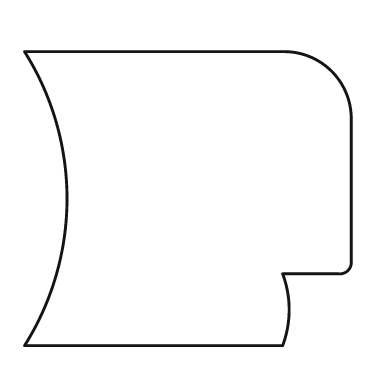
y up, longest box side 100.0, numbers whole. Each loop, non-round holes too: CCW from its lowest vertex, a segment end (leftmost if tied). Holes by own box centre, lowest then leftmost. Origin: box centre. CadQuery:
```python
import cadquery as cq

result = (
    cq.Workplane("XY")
    .moveTo(-50.0, -45.0)
    .lineTo(29.0, -45.0)
    .threePointArc((31.0, -34.0), (29.0, -23.0))
    .lineTo(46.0, -23.0)
    .threePointArc((49.0, -22.0), (50.0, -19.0))
    .lineTo(50.0, 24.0)
    .threePointArc((44.0, 39.0), (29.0, 45.0))
    .lineTo(-50.0, 45.0)
    .threePointArc((-37.0, 0.0), (-50.0, -45.0))
    .close()
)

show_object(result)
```